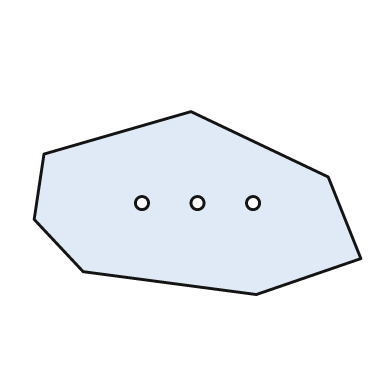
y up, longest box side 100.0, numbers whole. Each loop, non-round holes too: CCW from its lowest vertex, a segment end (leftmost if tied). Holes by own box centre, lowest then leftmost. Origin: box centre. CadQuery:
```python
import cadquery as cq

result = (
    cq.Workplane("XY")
    .moveTo(18.0, -28.0)
    .lineTo(50.0, -17.0)
    .lineTo(40.0, 8.0)
    .lineTo(-2.0, 28.0)
    .lineTo(-47.0, 15.0)
    .lineTo(-50.0, -5.0)
    .lineTo(-35.0, -21.0)
    .close()
    .moveTo(-17.0, 0.0)
    .circle(2.0)
    .moveTo(0.0, 0.0)
    .circle(2.0)
    .moveTo(17.0, 0.0)
    .circle(2.0)
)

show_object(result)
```